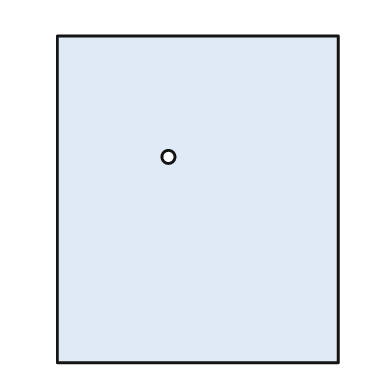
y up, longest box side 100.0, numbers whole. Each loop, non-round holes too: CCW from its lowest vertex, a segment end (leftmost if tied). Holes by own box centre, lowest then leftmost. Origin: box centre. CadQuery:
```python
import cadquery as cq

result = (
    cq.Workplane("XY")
    .moveTo(-43.0, -50.0)
    .lineTo(43.0, -50.0)
    .lineTo(43.0, 50.0)
    .lineTo(-43.0, 50.0)
    .close()
    .moveTo(-9.0, 13.0)
    .circle(2.0)
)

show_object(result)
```